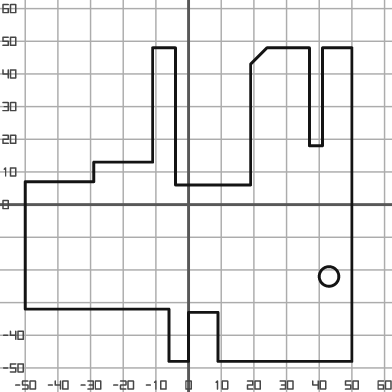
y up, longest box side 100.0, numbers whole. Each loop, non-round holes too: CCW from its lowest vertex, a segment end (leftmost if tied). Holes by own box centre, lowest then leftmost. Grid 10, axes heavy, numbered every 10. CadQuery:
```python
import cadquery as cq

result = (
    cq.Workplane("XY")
    .moveTo(-6.0, -48.0)
    .lineTo(0.0, -48.0)
    .lineTo(0.0, -33.0)
    .lineTo(9.0, -33.0)
    .lineTo(9.0, -48.0)
    .lineTo(50.0, -48.0)
    .lineTo(50.0, 48.0)
    .lineTo(41.0, 48.0)
    .lineTo(41.0, 18.0)
    .lineTo(37.0, 18.0)
    .lineTo(37.0, 48.0)
    .lineTo(24.0, 48.0)
    .lineTo(19.0, 43.0)
    .lineTo(19.0, 6.0)
    .lineTo(-4.0, 6.0)
    .lineTo(-4.0, 48.0)
    .lineTo(-11.0, 48.0)
    .lineTo(-11.0, 13.0)
    .lineTo(-29.0, 13.0)
    .lineTo(-29.0, 7.0)
    .lineTo(-50.0, 7.0)
    .lineTo(-50.0, -32.0)
    .lineTo(-6.0, -32.0)
    .close()
    .moveTo(43.0, -22.0)
    .circle(3.0)
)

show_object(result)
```